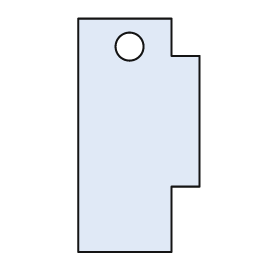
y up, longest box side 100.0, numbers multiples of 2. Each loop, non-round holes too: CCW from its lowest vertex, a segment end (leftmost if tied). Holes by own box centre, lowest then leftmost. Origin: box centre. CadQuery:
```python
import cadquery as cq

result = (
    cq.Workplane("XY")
    .moveTo(-26.0, -50.0)
    .lineTo(14.0, -50.0)
    .lineTo(14.0, -22.0)
    .lineTo(26.0, -22.0)
    .lineTo(26.0, 34.0)
    .lineTo(14.0, 34.0)
    .lineTo(14.0, 50.0)
    .lineTo(-26.0, 50.0)
    .close()
    .moveTo(-4.0, 38.0)
    .circle(6.0)
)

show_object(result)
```